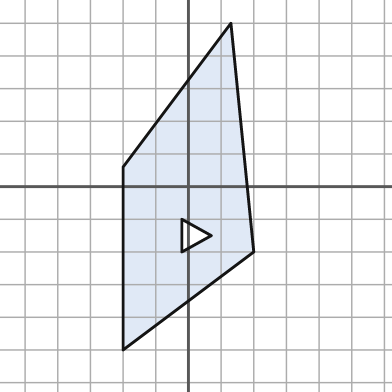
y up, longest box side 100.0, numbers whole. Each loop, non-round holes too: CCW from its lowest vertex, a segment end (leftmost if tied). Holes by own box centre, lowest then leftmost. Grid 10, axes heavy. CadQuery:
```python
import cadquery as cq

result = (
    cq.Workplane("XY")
    .moveTo(-20.0, -50.0)
    .lineTo(20.0, -20.0)
    .lineTo(13.0, 50.0)
    .lineTo(-20.0, 6.0)
    .close()
    .moveTo(-2.0, -20.0)
    .lineTo(7.0, -15.0)
    .lineTo(-2.0, -10.0)
    .close()
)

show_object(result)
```